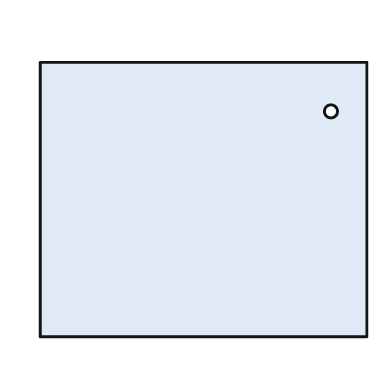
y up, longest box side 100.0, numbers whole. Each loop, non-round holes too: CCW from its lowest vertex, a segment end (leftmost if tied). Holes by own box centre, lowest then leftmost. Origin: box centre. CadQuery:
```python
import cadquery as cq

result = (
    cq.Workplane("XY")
    .moveTo(-50.0, -42.0)
    .lineTo(50.0, -42.0)
    .lineTo(50.0, 42.0)
    .lineTo(-50.0, 42.0)
    .close()
    .moveTo(39.0, 27.0)
    .circle(2.0)
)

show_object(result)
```